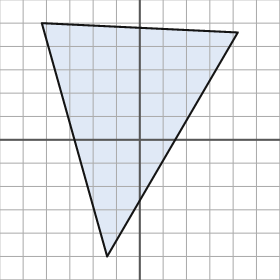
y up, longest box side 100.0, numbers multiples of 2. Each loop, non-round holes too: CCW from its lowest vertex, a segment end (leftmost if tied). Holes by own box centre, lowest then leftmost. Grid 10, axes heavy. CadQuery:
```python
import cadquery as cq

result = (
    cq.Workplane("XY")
    .moveTo(-14.0, -50.0)
    .lineTo(42.0, 46.0)
    .lineTo(-42.0, 50.0)
    .close()
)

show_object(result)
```